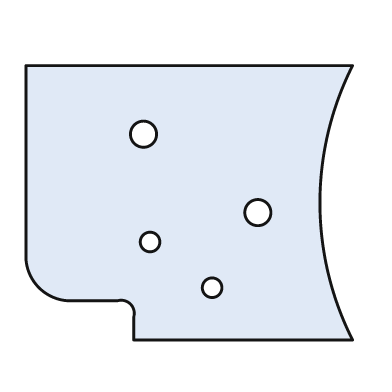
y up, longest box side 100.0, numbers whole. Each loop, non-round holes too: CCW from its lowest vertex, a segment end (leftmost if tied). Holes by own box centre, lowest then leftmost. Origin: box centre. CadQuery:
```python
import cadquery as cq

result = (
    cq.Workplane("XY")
    .moveTo(-17.0, -42.0)
    .lineTo(50.0, -42.0)
    .threePointArc((40.0, 0.0), (50.0, 42.0))
    .lineTo(-50.0, 42.0)
    .lineTo(-50.0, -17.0)
    .threePointArc((-46.0, -26.0), (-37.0, -30.0))
    .lineTo(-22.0, -30.0)
    .threePointArc((-18.0, -31.0), (-17.0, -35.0))
    .close()
    .moveTo(7.0, -26.0)
    .circle(3.0)
    .moveTo(-12.0, -12.0)
    .circle(3.0)
    .moveTo(21.0, -3.0)
    .circle(4.0)
    .moveTo(-14.0, 21.0)
    .circle(4.0)
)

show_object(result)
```